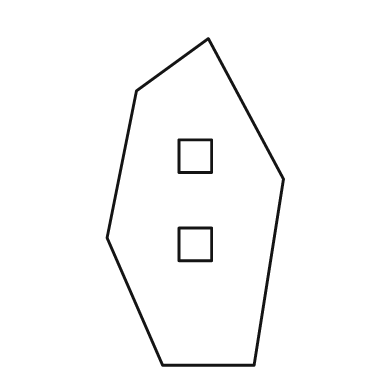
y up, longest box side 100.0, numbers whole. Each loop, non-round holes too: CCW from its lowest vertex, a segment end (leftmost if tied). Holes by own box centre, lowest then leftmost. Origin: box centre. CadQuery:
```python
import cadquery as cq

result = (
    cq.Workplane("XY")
    .moveTo(-10.0, -50.0)
    .lineTo(18.0, -50.0)
    .lineTo(27.0, 7.0)
    .lineTo(4.0, 50.0)
    .lineTo(-18.0, 34.0)
    .lineTo(-27.0, -11.0)
    .close()
    .moveTo(-5.0, -18.0)
    .lineTo(5.0, -18.0)
    .lineTo(5.0, -8.0)
    .lineTo(-5.0, -8.0)
    .close()
    .moveTo(-5.0, 9.0)
    .lineTo(5.0, 9.0)
    .lineTo(5.0, 19.0)
    .lineTo(-5.0, 19.0)
    .close()
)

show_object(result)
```